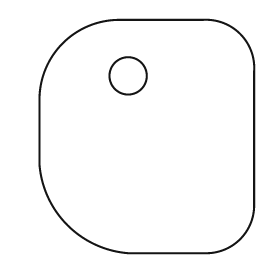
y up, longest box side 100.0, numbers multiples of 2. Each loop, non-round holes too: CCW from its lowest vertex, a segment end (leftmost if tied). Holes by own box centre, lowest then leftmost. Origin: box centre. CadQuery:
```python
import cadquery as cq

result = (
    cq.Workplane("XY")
    .moveTo(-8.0, -50.0)
    .lineTo(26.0, -50.0)
    .threePointArc((40.0, -44.0), (46.0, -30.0))
    .lineTo(46.0, 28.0)
    .threePointArc((40.0, 44.0), (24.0, 50.0))
    .lineTo(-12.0, 50.0)
    .threePointArc((-36.0, 40.0), (-46.0, 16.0))
    .lineTo(-46.0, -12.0)
    .threePointArc((-34.0, -38.0), (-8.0, -50.0))
    .close()
    .moveTo(-8.0, 26.0)
    .circle(8.0)
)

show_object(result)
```